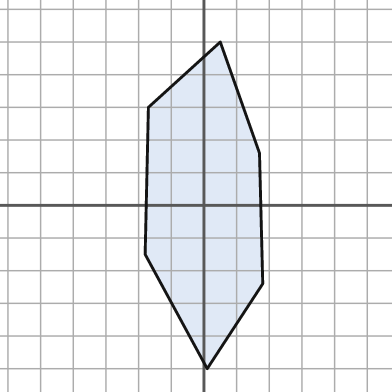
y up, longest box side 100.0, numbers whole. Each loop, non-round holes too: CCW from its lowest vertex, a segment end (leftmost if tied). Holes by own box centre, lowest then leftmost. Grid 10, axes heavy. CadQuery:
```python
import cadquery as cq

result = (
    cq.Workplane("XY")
    .moveTo(1.0, -50.0)
    .lineTo(18.0, -24.0)
    .lineTo(17.0, 16.0)
    .lineTo(5.0, 50.0)
    .lineTo(-17.0, 30.0)
    .lineTo(-18.0, -15.0)
    .close()
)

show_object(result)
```